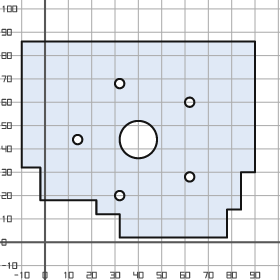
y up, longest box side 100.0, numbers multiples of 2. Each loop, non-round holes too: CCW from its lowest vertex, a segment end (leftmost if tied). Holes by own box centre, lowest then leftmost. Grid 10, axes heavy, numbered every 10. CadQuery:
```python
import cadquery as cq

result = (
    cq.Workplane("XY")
    .moveTo(32.0, 2.0)
    .lineTo(78.0, 2.0)
    .lineTo(78.0, 14.0)
    .lineTo(84.0, 14.0)
    .lineTo(84.0, 30.0)
    .lineTo(90.0, 30.0)
    .lineTo(90.0, 86.0)
    .lineTo(-10.0, 86.0)
    .lineTo(-10.0, 32.0)
    .lineTo(-2.0, 32.0)
    .lineTo(-2.0, 18.0)
    .lineTo(22.0, 18.0)
    .lineTo(22.0, 12.0)
    .lineTo(32.0, 12.0)
    .close()
    .moveTo(32.0, 20.0)
    .circle(2.0)
    .moveTo(62.0, 28.0)
    .circle(2.0)
    .moveTo(14.0, 44.0)
    .circle(2.0)
    .moveTo(40.0, 44.0)
    .circle(8.0)
    .moveTo(62.0, 60.0)
    .circle(2.0)
    .moveTo(32.0, 68.0)
    .circle(2.0)
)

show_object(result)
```